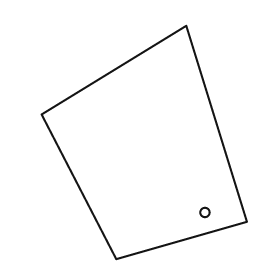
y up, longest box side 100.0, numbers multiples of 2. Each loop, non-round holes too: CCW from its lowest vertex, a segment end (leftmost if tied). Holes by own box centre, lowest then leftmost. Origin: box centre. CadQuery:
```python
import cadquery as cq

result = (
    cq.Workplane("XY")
    .moveTo(-12.0, -50.0)
    .lineTo(44.0, -34.0)
    .lineTo(18.0, 50.0)
    .lineTo(-44.0, 12.0)
    .close()
    .moveTo(26.0, -30.0)
    .circle(2.0)
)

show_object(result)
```